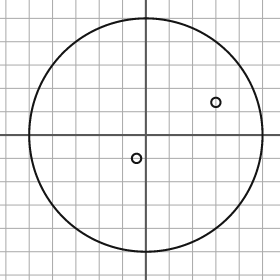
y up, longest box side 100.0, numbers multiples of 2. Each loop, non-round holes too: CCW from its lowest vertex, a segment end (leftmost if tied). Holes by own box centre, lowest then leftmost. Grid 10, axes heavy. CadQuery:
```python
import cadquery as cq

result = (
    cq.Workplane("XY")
    .moveTo(0.0, 0.0)
    .circle(50.0)
    .moveTo(-4.0, -10.0)
    .circle(2.0)
    .moveTo(30.0, 14.0)
    .circle(2.0)
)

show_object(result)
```